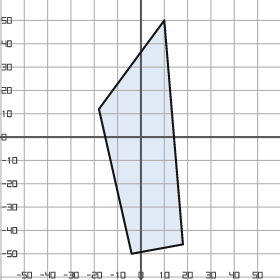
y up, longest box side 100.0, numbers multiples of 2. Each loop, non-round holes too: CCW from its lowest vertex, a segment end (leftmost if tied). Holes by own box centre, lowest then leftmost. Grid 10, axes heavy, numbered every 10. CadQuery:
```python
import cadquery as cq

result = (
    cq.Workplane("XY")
    .moveTo(-4.0, -50.0)
    .lineTo(18.0, -46.0)
    .lineTo(10.0, 50.0)
    .lineTo(-18.0, 12.0)
    .close()
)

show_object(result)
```